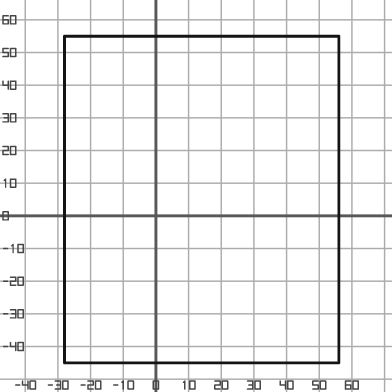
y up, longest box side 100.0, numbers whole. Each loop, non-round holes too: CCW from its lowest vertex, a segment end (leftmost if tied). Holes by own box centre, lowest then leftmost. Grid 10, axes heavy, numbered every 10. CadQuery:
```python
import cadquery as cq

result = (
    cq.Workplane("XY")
    .moveTo(-28.0, -45.0)
    .lineTo(56.0, -45.0)
    .lineTo(56.0, 55.0)
    .lineTo(-28.0, 55.0)
    .close()
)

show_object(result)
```